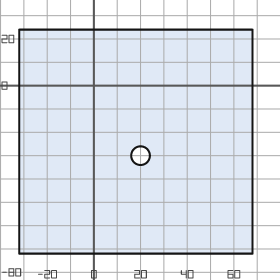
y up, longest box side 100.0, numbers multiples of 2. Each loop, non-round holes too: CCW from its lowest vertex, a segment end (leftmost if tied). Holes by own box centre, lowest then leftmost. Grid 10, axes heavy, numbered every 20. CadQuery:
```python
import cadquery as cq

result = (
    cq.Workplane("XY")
    .moveTo(-32.0, -72.0)
    .lineTo(68.0, -72.0)
    .lineTo(68.0, 24.0)
    .lineTo(-32.0, 24.0)
    .close()
    .moveTo(20.0, -30.0)
    .circle(4.0)
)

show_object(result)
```